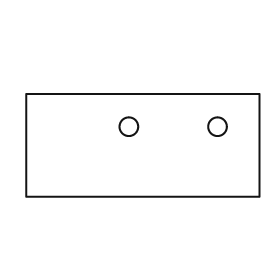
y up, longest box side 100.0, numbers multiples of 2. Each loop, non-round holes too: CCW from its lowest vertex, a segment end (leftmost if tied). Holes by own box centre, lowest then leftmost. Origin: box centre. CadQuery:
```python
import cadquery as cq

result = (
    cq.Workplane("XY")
    .moveTo(-50.0, -22.0)
    .lineTo(50.0, -22.0)
    .lineTo(50.0, 22.0)
    .lineTo(-50.0, 22.0)
    .close()
    .moveTo(-6.0, 8.0)
    .circle(4.0)
    .moveTo(32.0, 8.0)
    .circle(4.0)
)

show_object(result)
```